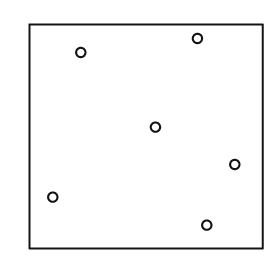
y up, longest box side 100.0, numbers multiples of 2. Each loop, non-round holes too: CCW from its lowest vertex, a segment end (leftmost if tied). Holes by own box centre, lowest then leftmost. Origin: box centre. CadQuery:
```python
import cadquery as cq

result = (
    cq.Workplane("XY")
    .moveTo(-50.0, -48.0)
    .lineTo(50.0, -48.0)
    .lineTo(50.0, 48.0)
    .lineTo(-50.0, 48.0)
    .close()
    .moveTo(26.0, -38.0)
    .circle(2.0)
    .moveTo(-40.0, -26.0)
    .circle(2.0)
    .moveTo(38.0, -12.0)
    .circle(2.0)
    .moveTo(4.0, 4.0)
    .circle(2.0)
    .moveTo(-28.0, 36.0)
    .circle(2.0)
    .moveTo(22.0, 42.0)
    .circle(2.0)
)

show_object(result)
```